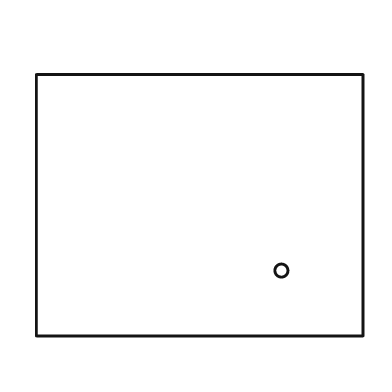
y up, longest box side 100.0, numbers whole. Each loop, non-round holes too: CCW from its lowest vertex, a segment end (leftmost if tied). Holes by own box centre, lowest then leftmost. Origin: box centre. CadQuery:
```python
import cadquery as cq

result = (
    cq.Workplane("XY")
    .moveTo(-50.0, -40.0)
    .lineTo(50.0, -40.0)
    .lineTo(50.0, 40.0)
    .lineTo(-50.0, 40.0)
    .close()
    .moveTo(25.0, -20.0)
    .circle(2.0)
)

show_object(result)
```